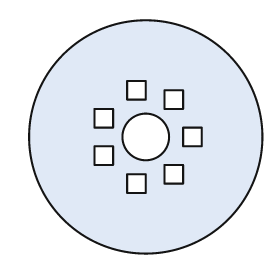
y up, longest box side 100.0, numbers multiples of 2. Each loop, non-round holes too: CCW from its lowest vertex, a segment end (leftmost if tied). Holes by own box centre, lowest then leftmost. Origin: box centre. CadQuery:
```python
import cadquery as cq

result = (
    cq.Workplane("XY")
    .moveTo(0.0, 0.0)
    .circle(50.0)
    .moveTo(-8.0, -24.0)
    .lineTo(0.0, -24.0)
    .lineTo(0.0, -16.0)
    .lineTo(-8.0, -16.0)
    .close()
    .moveTo(8.0, -20.0)
    .lineTo(16.0, -20.0)
    .lineTo(16.0, -12.0)
    .lineTo(8.0, -12.0)
    .close()
    .moveTo(-22.0, -12.0)
    .lineTo(-14.0, -12.0)
    .lineTo(-14.0, -4.0)
    .lineTo(-22.0, -4.0)
    .close()
    .moveTo(0.0, 0.0)
    .circle(10.0)
    .moveTo(16.0, -4.0)
    .lineTo(24.0, -4.0)
    .lineTo(24.0, 4.0)
    .lineTo(16.0, 4.0)
    .close()
    .moveTo(-22.0, 4.0)
    .lineTo(-14.0, 4.0)
    .lineTo(-14.0, 12.0)
    .lineTo(-22.0, 12.0)
    .close()
    .moveTo(8.0, 12.0)
    .lineTo(16.0, 12.0)
    .lineTo(16.0, 20.0)
    .lineTo(8.0, 20.0)
    .close()
    .moveTo(-8.0, 16.0)
    .lineTo(0.0, 16.0)
    .lineTo(0.0, 24.0)
    .lineTo(-8.0, 24.0)
    .close()
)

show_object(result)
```